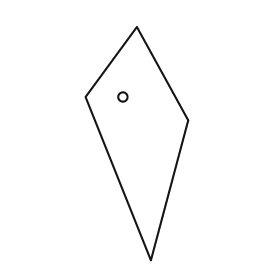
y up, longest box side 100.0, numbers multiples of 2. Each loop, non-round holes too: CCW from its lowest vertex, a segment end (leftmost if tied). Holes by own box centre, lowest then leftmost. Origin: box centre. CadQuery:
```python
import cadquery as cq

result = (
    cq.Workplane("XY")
    .moveTo(6.0, -50.0)
    .lineTo(22.0, 10.0)
    .lineTo(0.0, 50.0)
    .lineTo(-22.0, 20.0)
    .close()
    .moveTo(-6.0, 20.0)
    .circle(2.0)
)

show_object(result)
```